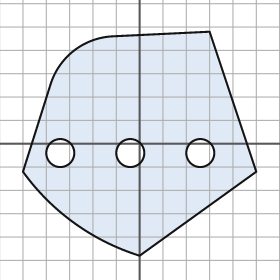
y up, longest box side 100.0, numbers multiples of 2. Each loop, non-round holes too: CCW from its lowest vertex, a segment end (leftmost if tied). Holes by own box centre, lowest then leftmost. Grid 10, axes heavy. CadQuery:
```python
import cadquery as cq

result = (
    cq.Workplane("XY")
    .moveTo(0.0, -48.0)
    .lineTo(50.0, -12.0)
    .lineTo(30.0, 48.0)
    .lineTo(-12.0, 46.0)
    .threePointArc((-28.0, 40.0), (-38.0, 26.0))
    .lineTo(-50.0, -12.0)
    .threePointArc((-28.0, -34.0), (0.0, -48.0))
    .close()
    .moveTo(-34.0, -4.0)
    .circle(6.0)
    .moveTo(-4.0, -4.0)
    .circle(6.0)
    .moveTo(26.0, -4.0)
    .circle(6.0)
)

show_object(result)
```